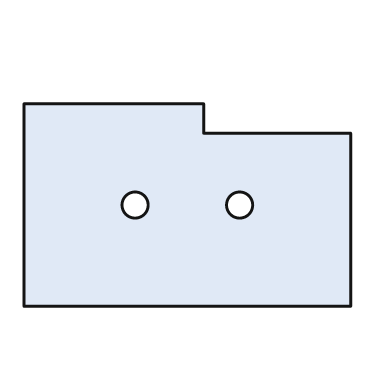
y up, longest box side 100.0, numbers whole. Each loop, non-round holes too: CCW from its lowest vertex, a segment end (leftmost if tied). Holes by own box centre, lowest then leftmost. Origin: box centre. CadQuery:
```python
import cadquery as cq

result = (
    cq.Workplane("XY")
    .moveTo(-50.0, -31.0)
    .lineTo(50.0, -31.0)
    .lineTo(50.0, 22.0)
    .lineTo(5.0, 22.0)
    .lineTo(5.0, 31.0)
    .lineTo(-50.0, 31.0)
    .close()
    .moveTo(-16.0, 0.0)
    .circle(4.0)
    .moveTo(16.0, 0.0)
    .circle(4.0)
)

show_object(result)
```